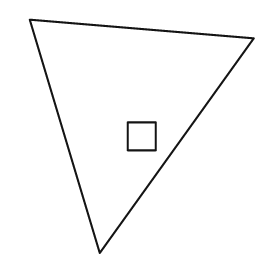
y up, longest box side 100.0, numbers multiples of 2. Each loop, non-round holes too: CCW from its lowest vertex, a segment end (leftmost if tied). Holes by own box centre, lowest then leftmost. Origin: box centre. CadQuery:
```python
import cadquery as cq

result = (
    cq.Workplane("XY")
    .moveTo(-18.0, -50.0)
    .lineTo(48.0, 42.0)
    .lineTo(-48.0, 50.0)
    .close()
    .moveTo(-6.0, -6.0)
    .lineTo(6.0, -6.0)
    .lineTo(6.0, 6.0)
    .lineTo(-6.0, 6.0)
    .close()
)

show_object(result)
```